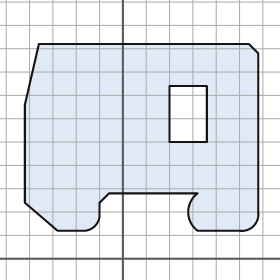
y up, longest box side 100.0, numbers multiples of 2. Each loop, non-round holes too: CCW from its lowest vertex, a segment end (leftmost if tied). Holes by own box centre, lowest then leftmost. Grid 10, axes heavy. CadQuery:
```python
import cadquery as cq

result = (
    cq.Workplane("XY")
    .moveTo(-28.0, 12.0)
    .lineTo(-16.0, 12.0)
    .threePointArc((-12.0, 14.0), (-10.0, 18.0))
    .lineTo(-10.0, 24.0)
    .lineTo(-6.0, 28.0)
    .lineTo(32.0, 28.0)
    .threePointArc((28.0, 20.0), (32.0, 12.0))
    .lineTo(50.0, 12.0)
    .threePointArc((56.0, 14.0), (58.0, 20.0))
    .lineTo(58.0, 88.0)
    .lineTo(54.0, 92.0)
    .lineTo(-36.0, 92.0)
    .lineTo(-42.0, 66.0)
    .lineTo(-42.0, 24.0)
    .close()
    .moveTo(20.0, 50.0)
    .lineTo(36.0, 50.0)
    .lineTo(36.0, 74.0)
    .lineTo(20.0, 74.0)
    .close()
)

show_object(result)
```